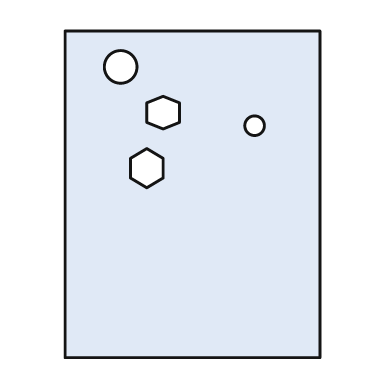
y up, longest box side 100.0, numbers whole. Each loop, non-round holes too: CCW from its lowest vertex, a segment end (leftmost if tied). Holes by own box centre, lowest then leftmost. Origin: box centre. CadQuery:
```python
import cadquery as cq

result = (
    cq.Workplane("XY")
    .moveTo(-39.0, -50.0)
    .lineTo(39.0, -50.0)
    .lineTo(39.0, 50.0)
    .lineTo(-39.0, 50.0)
    .close()
    .moveTo(-14.0, 2.0)
    .lineTo(-9.0, 5.0)
    .lineTo(-9.0, 11.0)
    .lineTo(-14.0, 14.0)
    .lineTo(-19.0, 11.0)
    .lineTo(-19.0, 5.0)
    .close()
    .moveTo(19.0, 21.0)
    .circle(3.0)
    .moveTo(-9.0, 20.0)
    .lineTo(-4.0, 22.0)
    .lineTo(-4.0, 28.0)
    .lineTo(-9.0, 30.0)
    .lineTo(-14.0, 28.0)
    .lineTo(-14.0, 22.0)
    .close()
    .moveTo(-22.0, 39.0)
    .circle(5.0)
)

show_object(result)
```